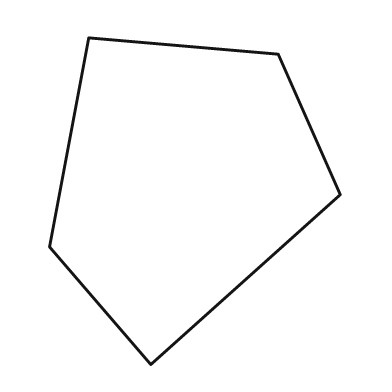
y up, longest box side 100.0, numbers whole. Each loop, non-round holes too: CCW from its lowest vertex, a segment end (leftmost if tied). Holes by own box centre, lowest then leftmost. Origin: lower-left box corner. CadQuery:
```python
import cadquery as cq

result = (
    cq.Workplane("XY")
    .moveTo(31.0, 0.0)
    .lineTo(89.0, 52.0)
    .lineTo(70.0, 95.0)
    .lineTo(12.0, 100.0)
    .lineTo(0.0, 36.0)
    .close()
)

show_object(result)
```